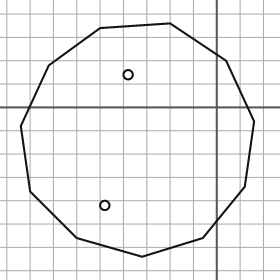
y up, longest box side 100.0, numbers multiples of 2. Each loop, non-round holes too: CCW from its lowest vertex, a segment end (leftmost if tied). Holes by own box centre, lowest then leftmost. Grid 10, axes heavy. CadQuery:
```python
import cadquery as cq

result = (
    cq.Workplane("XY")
    .moveTo(-32.0, -64.0)
    .lineTo(-6.0, -56.0)
    .lineTo(12.0, -34.0)
    .lineTo(16.0, -6.0)
    .lineTo(4.0, 20.0)
    .lineTo(-20.0, 36.0)
    .lineTo(-50.0, 34.0)
    .lineTo(-72.0, 18.0)
    .lineTo(-84.0, -8.0)
    .lineTo(-80.0, -36.0)
    .lineTo(-60.0, -56.0)
    .close()
    .moveTo(-48.0, -42.0)
    .circle(2.0)
    .moveTo(-38.0, 14.0)
    .circle(2.0)
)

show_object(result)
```